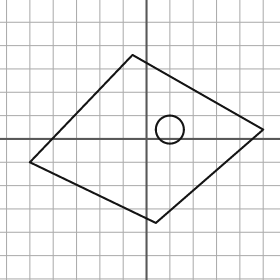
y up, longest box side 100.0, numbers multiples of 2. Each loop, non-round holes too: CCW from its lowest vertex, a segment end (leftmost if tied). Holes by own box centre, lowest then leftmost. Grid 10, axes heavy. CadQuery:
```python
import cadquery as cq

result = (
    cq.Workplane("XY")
    .moveTo(4.0, -36.0)
    .lineTo(50.0, 4.0)
    .lineTo(-6.0, 36.0)
    .lineTo(-50.0, -10.0)
    .close()
    .moveTo(10.0, 4.0)
    .circle(6.0)
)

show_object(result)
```